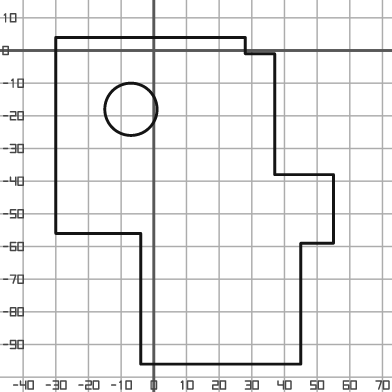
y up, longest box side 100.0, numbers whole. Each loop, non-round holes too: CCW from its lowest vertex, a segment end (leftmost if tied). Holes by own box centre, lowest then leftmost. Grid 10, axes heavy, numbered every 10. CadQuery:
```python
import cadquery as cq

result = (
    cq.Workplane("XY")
    .moveTo(-4.0, -96.0)
    .lineTo(45.0, -96.0)
    .lineTo(45.0, -59.0)
    .lineTo(55.0, -59.0)
    .lineTo(55.0, -38.0)
    .lineTo(37.0, -38.0)
    .lineTo(37.0, -1.0)
    .lineTo(28.0, -1.0)
    .lineTo(28.0, 4.0)
    .lineTo(-30.0, 4.0)
    .lineTo(-30.0, -56.0)
    .lineTo(-4.0, -56.0)
    .close()
    .moveTo(-7.0, -18.0)
    .circle(8.0)
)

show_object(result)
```